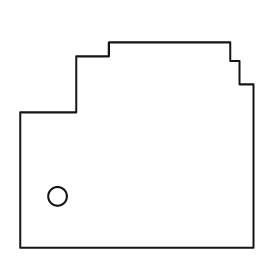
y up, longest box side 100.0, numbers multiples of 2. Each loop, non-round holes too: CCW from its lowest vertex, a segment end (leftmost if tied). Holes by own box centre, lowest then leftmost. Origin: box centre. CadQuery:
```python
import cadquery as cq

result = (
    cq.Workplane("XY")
    .moveTo(-50.0, -44.0)
    .lineTo(50.0, -44.0)
    .lineTo(50.0, 26.0)
    .lineTo(44.0, 26.0)
    .lineTo(44.0, 36.0)
    .lineTo(40.0, 36.0)
    .lineTo(40.0, 44.0)
    .lineTo(-12.0, 44.0)
    .lineTo(-12.0, 38.0)
    .lineTo(-26.0, 38.0)
    .lineTo(-26.0, 14.0)
    .lineTo(-50.0, 14.0)
    .close()
    .moveTo(-34.0, -22.0)
    .circle(4.0)
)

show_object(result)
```